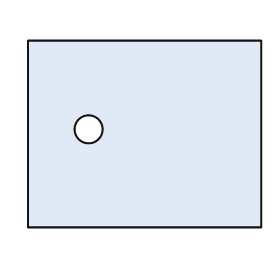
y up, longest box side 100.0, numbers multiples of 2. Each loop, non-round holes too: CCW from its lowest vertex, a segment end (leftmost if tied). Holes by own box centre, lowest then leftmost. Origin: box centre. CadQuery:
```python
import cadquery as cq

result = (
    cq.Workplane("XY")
    .moveTo(-50.0, -40.0)
    .lineTo(50.0, -40.0)
    .lineTo(50.0, 40.0)
    .lineTo(-50.0, 40.0)
    .close()
    .moveTo(-24.0, 2.0)
    .circle(6.0)
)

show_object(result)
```